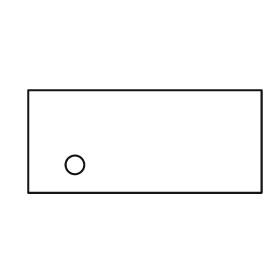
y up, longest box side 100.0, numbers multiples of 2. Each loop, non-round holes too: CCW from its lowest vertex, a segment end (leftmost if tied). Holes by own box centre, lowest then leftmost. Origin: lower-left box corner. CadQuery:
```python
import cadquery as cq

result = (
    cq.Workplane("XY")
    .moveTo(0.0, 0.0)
    .lineTo(100.0, 0.0)
    .lineTo(100.0, 44.0)
    .lineTo(0.0, 44.0)
    .close()
    .moveTo(20.0, 12.0)
    .circle(4.0)
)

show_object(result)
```